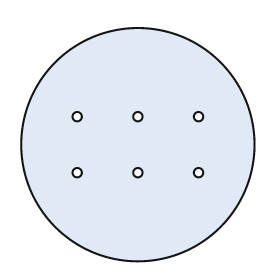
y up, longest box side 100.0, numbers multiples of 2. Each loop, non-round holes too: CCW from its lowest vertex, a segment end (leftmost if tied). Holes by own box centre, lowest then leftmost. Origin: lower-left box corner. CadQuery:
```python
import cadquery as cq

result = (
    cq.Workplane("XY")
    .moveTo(50.0, 50.0)
    .circle(50.0)
    .moveTo(24.0, 38.0)
    .circle(2.0)
    .moveTo(50.0, 38.0)
    .circle(2.0)
    .moveTo(76.0, 38.0)
    .circle(2.0)
    .moveTo(24.0, 62.0)
    .circle(2.0)
    .moveTo(50.0, 62.0)
    .circle(2.0)
    .moveTo(76.0, 62.0)
    .circle(2.0)
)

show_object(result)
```